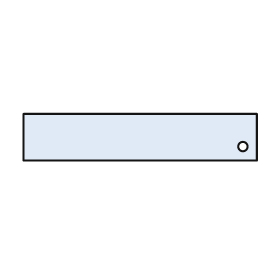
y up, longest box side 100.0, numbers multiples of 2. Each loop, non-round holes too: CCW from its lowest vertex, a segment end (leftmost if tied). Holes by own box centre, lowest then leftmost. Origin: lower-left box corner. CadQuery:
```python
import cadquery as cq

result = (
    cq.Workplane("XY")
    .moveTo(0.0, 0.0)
    .lineTo(100.0, 0.0)
    .lineTo(100.0, 20.0)
    .lineTo(0.0, 20.0)
    .close()
    .moveTo(94.0, 6.0)
    .circle(2.0)
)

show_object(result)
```